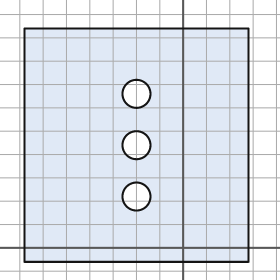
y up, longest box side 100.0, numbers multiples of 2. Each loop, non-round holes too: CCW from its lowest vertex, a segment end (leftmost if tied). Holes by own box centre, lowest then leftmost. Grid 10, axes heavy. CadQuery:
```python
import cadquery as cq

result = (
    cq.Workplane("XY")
    .moveTo(-68.0, -6.0)
    .lineTo(28.0, -6.0)
    .lineTo(28.0, 94.0)
    .lineTo(-68.0, 94.0)
    .close()
    .moveTo(-20.0, 22.0)
    .circle(6.0)
    .moveTo(-20.0, 44.0)
    .circle(6.0)
    .moveTo(-20.0, 66.0)
    .circle(6.0)
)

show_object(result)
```